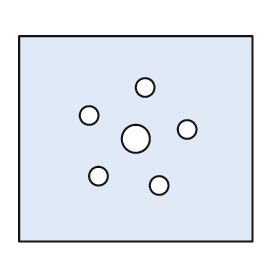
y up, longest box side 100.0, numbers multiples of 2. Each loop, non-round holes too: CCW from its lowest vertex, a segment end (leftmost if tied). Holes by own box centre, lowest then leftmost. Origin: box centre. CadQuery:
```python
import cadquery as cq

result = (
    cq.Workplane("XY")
    .moveTo(-50.0, -44.0)
    .lineTo(50.0, -44.0)
    .lineTo(50.0, 44.0)
    .lineTo(-50.0, 44.0)
    .close()
    .moveTo(10.0, -20.0)
    .circle(4.0)
    .moveTo(-16.0, -16.0)
    .circle(4.0)
    .moveTo(0.0, 0.0)
    .circle(6.0)
    .moveTo(22.0, 4.0)
    .circle(4.0)
    .moveTo(-20.0, 10.0)
    .circle(4.0)
    .moveTo(4.0, 22.0)
    .circle(4.0)
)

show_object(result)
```